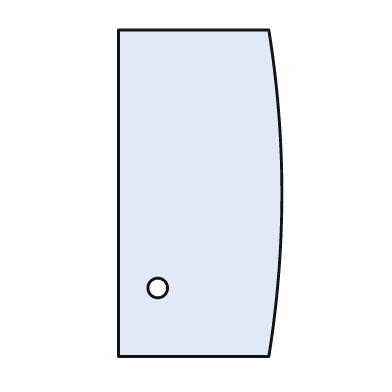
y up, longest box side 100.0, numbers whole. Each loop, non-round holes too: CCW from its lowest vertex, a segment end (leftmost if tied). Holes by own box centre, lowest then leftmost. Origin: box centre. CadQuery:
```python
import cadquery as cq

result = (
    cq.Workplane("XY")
    .moveTo(-25.0, -50.0)
    .lineTo(21.0, -50.0)
    .threePointArc((25.0, 0.0), (21.0, 50.0))
    .lineTo(-25.0, 50.0)
    .close()
    .moveTo(-13.0, -29.0)
    .circle(3.0)
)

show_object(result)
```